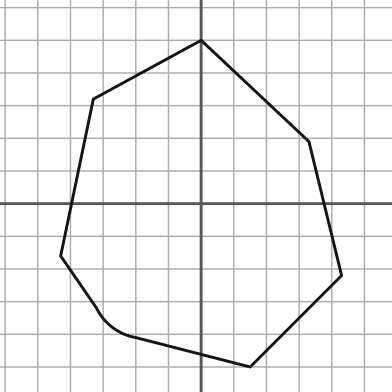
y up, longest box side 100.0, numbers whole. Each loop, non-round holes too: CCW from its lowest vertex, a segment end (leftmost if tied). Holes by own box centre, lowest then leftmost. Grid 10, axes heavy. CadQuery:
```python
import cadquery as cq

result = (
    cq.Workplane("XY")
    .moveTo(15.0, -50.0)
    .lineTo(43.0, -22.0)
    .lineTo(33.0, 19.0)
    .lineTo(0.0, 50.0)
    .lineTo(-33.0, 32.0)
    .lineTo(-43.0, -16.0)
    .lineTo(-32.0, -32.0)
    .threePointArc((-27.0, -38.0), (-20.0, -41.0))
    .close()
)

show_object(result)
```